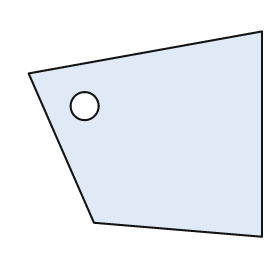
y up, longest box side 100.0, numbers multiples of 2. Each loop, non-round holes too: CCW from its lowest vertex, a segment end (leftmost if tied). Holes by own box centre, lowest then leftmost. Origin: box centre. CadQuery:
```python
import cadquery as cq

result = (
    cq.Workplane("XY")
    .moveTo(50.0, -44.0)
    .lineTo(50.0, 44.0)
    .lineTo(-50.0, 26.0)
    .lineTo(-22.0, -38.0)
    .close()
    .moveTo(-26.0, 12.0)
    .circle(6.0)
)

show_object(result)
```